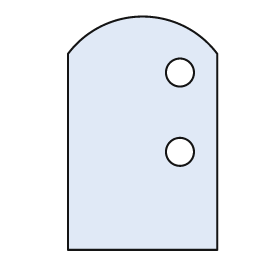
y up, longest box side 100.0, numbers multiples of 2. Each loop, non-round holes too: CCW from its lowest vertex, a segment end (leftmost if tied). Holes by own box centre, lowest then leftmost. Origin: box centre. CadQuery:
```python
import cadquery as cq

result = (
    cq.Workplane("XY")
    .moveTo(-32.0, -50.0)
    .lineTo(32.0, -50.0)
    .lineTo(32.0, 34.0)
    .threePointArc((0.0, 50.0), (-32.0, 34.0))
    .close()
    .moveTo(16.0, -8.0)
    .circle(6.0)
    .moveTo(16.0, 26.0)
    .circle(6.0)
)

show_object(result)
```